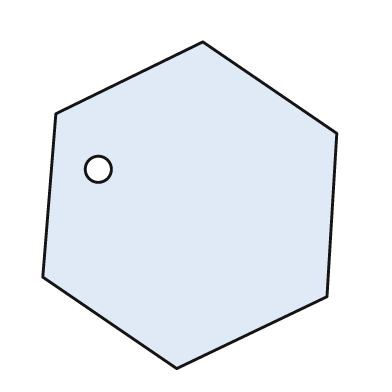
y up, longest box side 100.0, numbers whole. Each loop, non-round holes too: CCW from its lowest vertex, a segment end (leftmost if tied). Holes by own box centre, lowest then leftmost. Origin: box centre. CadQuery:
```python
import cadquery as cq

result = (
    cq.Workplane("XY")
    .moveTo(-4.0, -50.0)
    .lineTo(42.0, -28.0)
    .lineTo(45.0, 22.0)
    .lineTo(4.0, 50.0)
    .lineTo(-41.0, 28.0)
    .lineTo(-45.0, -22.0)
    .close()
    .moveTo(-28.0, 11.0)
    .circle(4.0)
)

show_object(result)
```